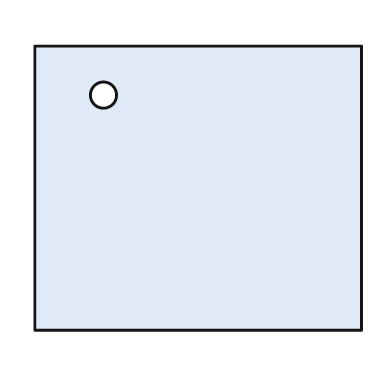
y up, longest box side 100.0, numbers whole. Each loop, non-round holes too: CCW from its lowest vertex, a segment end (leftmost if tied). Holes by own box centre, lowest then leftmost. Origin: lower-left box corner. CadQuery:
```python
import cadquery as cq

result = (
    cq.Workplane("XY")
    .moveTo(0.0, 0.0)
    .lineTo(100.0, 0.0)
    .lineTo(100.0, 87.0)
    .lineTo(0.0, 87.0)
    .close()
    .moveTo(21.0, 72.0)
    .circle(4.0)
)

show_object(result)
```